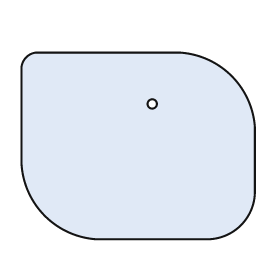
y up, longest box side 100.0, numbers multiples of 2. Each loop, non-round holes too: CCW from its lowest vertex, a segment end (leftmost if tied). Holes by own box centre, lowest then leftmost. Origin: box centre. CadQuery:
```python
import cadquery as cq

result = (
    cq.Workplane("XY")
    .moveTo(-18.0, -40.0)
    .lineTo(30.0, -40.0)
    .threePointArc((44.0, -34.0), (50.0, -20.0))
    .lineTo(50.0, 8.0)
    .threePointArc((40.0, 30.0), (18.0, 40.0))
    .lineTo(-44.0, 40.0)
    .threePointArc((-48.0, 38.0), (-50.0, 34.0))
    .lineTo(-50.0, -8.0)
    .threePointArc((-40.0, -30.0), (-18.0, -40.0))
    .close()
    .moveTo(6.0, 18.0)
    .circle(2.0)
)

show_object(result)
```